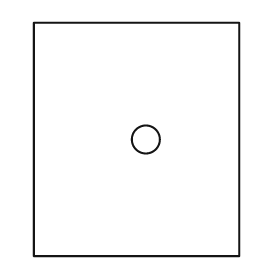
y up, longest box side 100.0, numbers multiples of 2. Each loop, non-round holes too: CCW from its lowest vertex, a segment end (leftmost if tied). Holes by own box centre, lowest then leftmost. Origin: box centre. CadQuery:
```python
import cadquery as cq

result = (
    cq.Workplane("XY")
    .moveTo(-44.0, -50.0)
    .lineTo(44.0, -50.0)
    .lineTo(44.0, 50.0)
    .lineTo(-44.0, 50.0)
    .close()
    .moveTo(4.0, 0.0)
    .circle(6.0)
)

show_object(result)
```